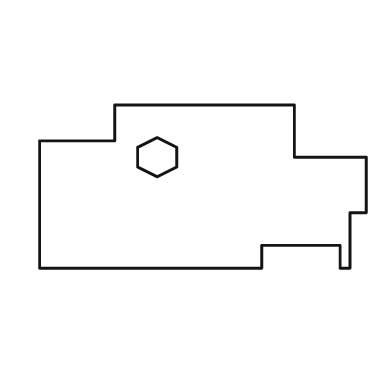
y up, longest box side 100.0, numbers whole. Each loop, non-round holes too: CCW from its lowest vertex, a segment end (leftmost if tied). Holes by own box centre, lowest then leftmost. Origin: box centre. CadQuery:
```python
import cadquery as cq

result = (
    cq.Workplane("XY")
    .moveTo(-50.0, -25.0)
    .lineTo(18.0, -25.0)
    .lineTo(18.0, -18.0)
    .lineTo(42.0, -18.0)
    .lineTo(42.0, -25.0)
    .lineTo(45.0, -25.0)
    .lineTo(45.0, -8.0)
    .lineTo(50.0, -8.0)
    .lineTo(50.0, 9.0)
    .lineTo(28.0, 9.0)
    .lineTo(28.0, 25.0)
    .lineTo(-27.0, 25.0)
    .lineTo(-27.0, 14.0)
    .lineTo(-50.0, 14.0)
    .close()
    .moveTo(-14.0, 3.0)
    .lineTo(-8.0, 6.0)
    .lineTo(-8.0, 12.0)
    .lineTo(-14.0, 15.0)
    .lineTo(-20.0, 12.0)
    .lineTo(-20.0, 6.0)
    .close()
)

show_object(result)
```